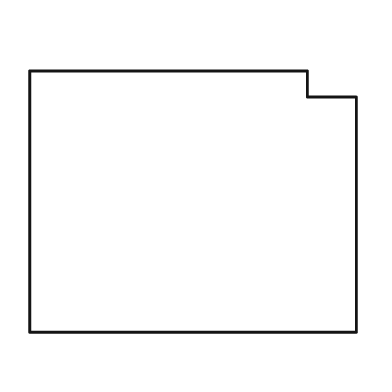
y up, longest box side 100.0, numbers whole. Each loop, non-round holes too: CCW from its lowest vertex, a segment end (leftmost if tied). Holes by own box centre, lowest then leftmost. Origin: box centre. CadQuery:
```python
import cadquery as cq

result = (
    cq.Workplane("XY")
    .moveTo(-50.0, -40.0)
    .lineTo(50.0, -40.0)
    .lineTo(50.0, 32.0)
    .lineTo(35.0, 32.0)
    .lineTo(35.0, 40.0)
    .lineTo(-50.0, 40.0)
    .close()
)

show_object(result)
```